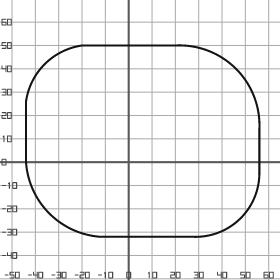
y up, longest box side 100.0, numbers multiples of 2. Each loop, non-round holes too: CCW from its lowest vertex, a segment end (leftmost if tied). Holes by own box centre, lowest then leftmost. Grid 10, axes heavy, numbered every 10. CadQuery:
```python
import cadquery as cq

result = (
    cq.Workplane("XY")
    .moveTo(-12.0, -32.0)
    .lineTo(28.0, -32.0)
    .threePointArc((48.0, -24.0), (56.0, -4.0))
    .lineTo(56.0, 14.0)
    .threePointArc((46.0, 40.0), (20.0, 50.0))
    .lineTo(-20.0, 50.0)
    .threePointArc((-36.0, 42.0), (-44.0, 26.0))
    .lineTo(-44.0, 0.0)
    .threePointArc((-34.0, -22.0), (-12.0, -32.0))
    .close()
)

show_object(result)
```